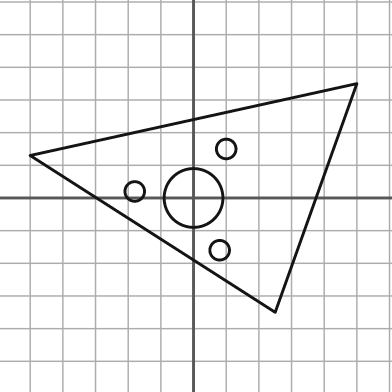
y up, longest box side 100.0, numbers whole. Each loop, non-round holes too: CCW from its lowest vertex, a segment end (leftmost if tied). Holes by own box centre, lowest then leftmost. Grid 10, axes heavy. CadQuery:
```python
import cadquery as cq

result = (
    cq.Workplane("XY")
    .moveTo(25.0, -35.0)
    .lineTo(50.0, 35.0)
    .lineTo(-50.0, 13.0)
    .close()
    .moveTo(8.0, -16.0)
    .circle(3.0)
    .moveTo(0.0, 0.0)
    .circle(9.0)
    .moveTo(-18.0, 2.0)
    .circle(3.0)
    .moveTo(10.0, 15.0)
    .circle(3.0)
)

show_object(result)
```